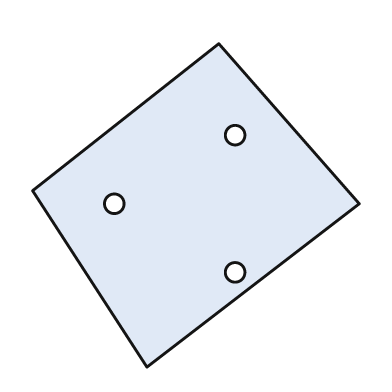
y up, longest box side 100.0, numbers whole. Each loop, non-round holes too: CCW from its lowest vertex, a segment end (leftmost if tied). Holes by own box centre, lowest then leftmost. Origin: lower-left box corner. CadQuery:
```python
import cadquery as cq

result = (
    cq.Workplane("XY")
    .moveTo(35.0, 0.0)
    .lineTo(100.0, 50.0)
    .lineTo(57.0, 99.0)
    .lineTo(0.0, 54.0)
    .close()
    .moveTo(62.0, 29.0)
    .circle(3.0)
    .moveTo(25.0, 50.0)
    .circle(3.0)
    .moveTo(62.0, 71.0)
    .circle(3.0)
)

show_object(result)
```